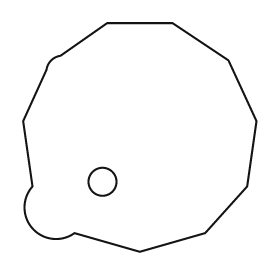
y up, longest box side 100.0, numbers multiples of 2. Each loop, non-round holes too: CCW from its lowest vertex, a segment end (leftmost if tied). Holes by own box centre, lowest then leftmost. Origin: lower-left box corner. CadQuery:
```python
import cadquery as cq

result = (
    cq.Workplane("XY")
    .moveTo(50.0, 0.0)
    .lineTo(78.0, 8.0)
    .lineTo(96.0, 28.0)
    .lineTo(100.0, 56.0)
    .lineTo(88.0, 82.0)
    .lineTo(64.0, 98.0)
    .lineTo(36.0, 98.0)
    .lineTo(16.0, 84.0)
    .threePointArc((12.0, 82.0), (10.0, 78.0))
    .lineTo(0.0, 56.0)
    .lineTo(4.0, 28.0)
    .threePointArc((4.0, 10.0), (22.0, 8.0))
    .close()
    .moveTo(34.0, 30.0)
    .circle(6.0)
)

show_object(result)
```